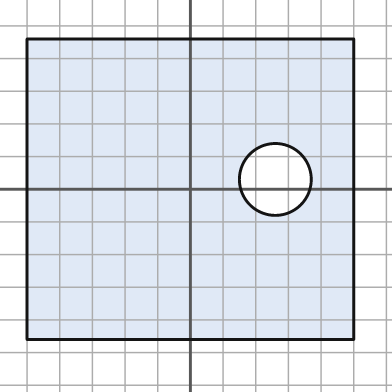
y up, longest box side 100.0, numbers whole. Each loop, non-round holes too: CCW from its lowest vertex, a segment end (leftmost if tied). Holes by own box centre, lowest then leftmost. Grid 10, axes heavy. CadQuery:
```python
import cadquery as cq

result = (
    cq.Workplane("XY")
    .moveTo(-50.0, -46.0)
    .lineTo(50.0, -46.0)
    .lineTo(50.0, 46.0)
    .lineTo(-50.0, 46.0)
    .close()
    .moveTo(26.0, 3.0)
    .circle(11.0)
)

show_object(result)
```